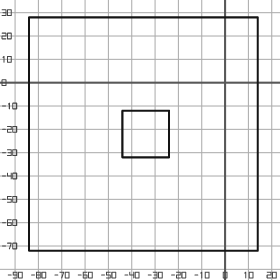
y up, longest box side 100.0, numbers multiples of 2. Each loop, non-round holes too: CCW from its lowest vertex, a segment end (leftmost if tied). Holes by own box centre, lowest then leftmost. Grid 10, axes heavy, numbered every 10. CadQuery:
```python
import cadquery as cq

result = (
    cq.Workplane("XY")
    .moveTo(-84.0, -72.0)
    .lineTo(14.0, -72.0)
    .lineTo(14.0, 28.0)
    .lineTo(-84.0, 28.0)
    .close()
    .moveTo(-44.0, -32.0)
    .lineTo(-24.0, -32.0)
    .lineTo(-24.0, -12.0)
    .lineTo(-44.0, -12.0)
    .close()
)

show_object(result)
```